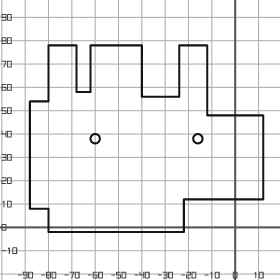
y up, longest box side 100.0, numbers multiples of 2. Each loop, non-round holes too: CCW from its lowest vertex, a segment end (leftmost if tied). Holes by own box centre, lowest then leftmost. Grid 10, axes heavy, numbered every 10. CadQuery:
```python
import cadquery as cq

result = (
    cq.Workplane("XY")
    .moveTo(-80.0, -2.0)
    .lineTo(-22.0, -2.0)
    .lineTo(-22.0, 12.0)
    .lineTo(12.0, 12.0)
    .lineTo(12.0, 48.0)
    .lineTo(-12.0, 48.0)
    .lineTo(-12.0, 78.0)
    .lineTo(-24.0, 78.0)
    .lineTo(-24.0, 56.0)
    .lineTo(-40.0, 56.0)
    .lineTo(-40.0, 78.0)
    .lineTo(-62.0, 78.0)
    .lineTo(-62.0, 58.0)
    .lineTo(-68.0, 58.0)
    .lineTo(-68.0, 78.0)
    .lineTo(-80.0, 78.0)
    .lineTo(-80.0, 54.0)
    .lineTo(-88.0, 54.0)
    .lineTo(-88.0, 8.0)
    .lineTo(-80.0, 8.0)
    .close()
    .moveTo(-60.0, 38.0)
    .circle(2.0)
    .moveTo(-16.0, 38.0)
    .circle(2.0)
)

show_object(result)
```